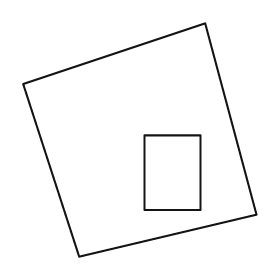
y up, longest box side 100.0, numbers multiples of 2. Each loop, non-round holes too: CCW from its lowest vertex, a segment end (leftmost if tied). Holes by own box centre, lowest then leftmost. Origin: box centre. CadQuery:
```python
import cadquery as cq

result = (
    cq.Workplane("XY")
    .moveTo(-26.0, -50.0)
    .lineTo(50.0, -32.0)
    .lineTo(28.0, 50.0)
    .lineTo(-50.0, 24.0)
    .close()
    .moveTo(2.0, -30.0)
    .lineTo(26.0, -30.0)
    .lineTo(26.0, 2.0)
    .lineTo(2.0, 2.0)
    .close()
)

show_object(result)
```